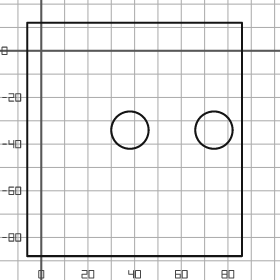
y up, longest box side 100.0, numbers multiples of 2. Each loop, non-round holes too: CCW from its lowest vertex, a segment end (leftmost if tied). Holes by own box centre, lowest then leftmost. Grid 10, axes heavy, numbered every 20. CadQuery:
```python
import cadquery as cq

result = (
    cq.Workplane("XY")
    .moveTo(-6.0, -88.0)
    .lineTo(86.0, -88.0)
    .lineTo(86.0, 12.0)
    .lineTo(-6.0, 12.0)
    .close()
    .moveTo(38.0, -34.0)
    .circle(8.0)
    .moveTo(74.0, -34.0)
    .circle(8.0)
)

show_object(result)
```